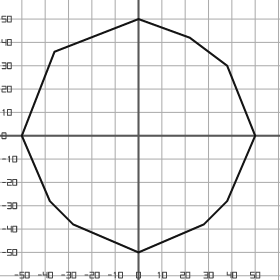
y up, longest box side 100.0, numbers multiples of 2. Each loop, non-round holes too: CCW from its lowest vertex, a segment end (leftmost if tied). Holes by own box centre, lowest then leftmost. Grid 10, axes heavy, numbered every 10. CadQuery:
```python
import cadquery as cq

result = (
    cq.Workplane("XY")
    .moveTo(0.0, -50.0)
    .lineTo(28.0, -38.0)
    .lineTo(38.0, -28.0)
    .lineTo(50.0, 0.0)
    .lineTo(38.0, 30.0)
    .lineTo(22.0, 42.0)
    .lineTo(0.0, 50.0)
    .lineTo(-36.0, 36.0)
    .lineTo(-50.0, 0.0)
    .lineTo(-38.0, -28.0)
    .lineTo(-28.0, -38.0)
    .close()
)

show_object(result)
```